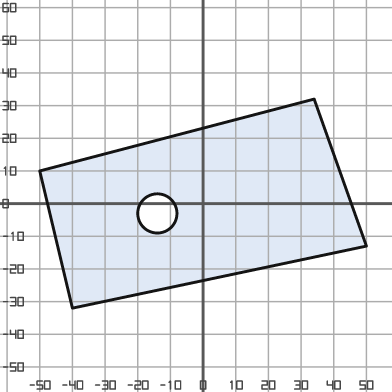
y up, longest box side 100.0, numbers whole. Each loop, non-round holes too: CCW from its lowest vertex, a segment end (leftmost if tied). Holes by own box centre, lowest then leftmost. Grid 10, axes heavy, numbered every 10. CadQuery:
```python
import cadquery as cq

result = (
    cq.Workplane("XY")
    .moveTo(-40.0, -32.0)
    .lineTo(50.0, -13.0)
    .lineTo(34.0, 32.0)
    .lineTo(-50.0, 10.0)
    .close()
    .moveTo(-14.0, -3.0)
    .circle(6.0)
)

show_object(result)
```